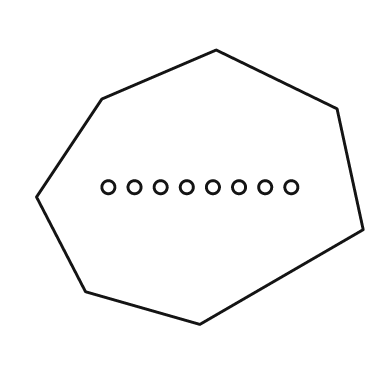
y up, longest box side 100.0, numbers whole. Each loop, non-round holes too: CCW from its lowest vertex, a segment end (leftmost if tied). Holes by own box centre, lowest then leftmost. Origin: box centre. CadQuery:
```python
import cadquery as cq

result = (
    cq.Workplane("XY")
    .moveTo(0.0, -42.0)
    .lineTo(50.0, -13.0)
    .lineTo(42.0, 24.0)
    .lineTo(5.0, 42.0)
    .lineTo(-30.0, 27.0)
    .lineTo(-50.0, -3.0)
    .lineTo(-35.0, -32.0)
    .close()
    .moveTo(-28.0, 0.0)
    .circle(2.0)
    .moveTo(-20.0, 0.0)
    .circle(2.0)
    .moveTo(-12.0, 0.0)
    .circle(2.0)
    .moveTo(-4.0, 0.0)
    .circle(2.0)
    .moveTo(4.0, 0.0)
    .circle(2.0)
    .moveTo(12.0, 0.0)
    .circle(2.0)
    .moveTo(20.0, 0.0)
    .circle(2.0)
    .moveTo(28.0, 0.0)
    .circle(2.0)
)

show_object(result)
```